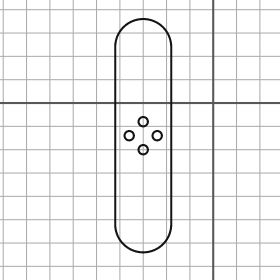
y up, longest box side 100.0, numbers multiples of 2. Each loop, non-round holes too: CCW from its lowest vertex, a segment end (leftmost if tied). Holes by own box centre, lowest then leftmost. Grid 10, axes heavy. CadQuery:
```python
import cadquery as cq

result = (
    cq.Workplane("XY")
    .moveTo(-42.0, -52.0)
    .threePointArc((-30.0, -64.0), (-18.0, -52.0))
    .lineTo(-18.0, 24.0)
    .threePointArc((-30.0, 36.0), (-42.0, 24.0))
    .close()
    .moveTo(-30.0, -20.0)
    .circle(2.0)
    .moveTo(-36.0, -14.0)
    .circle(2.0)
    .moveTo(-24.0, -14.0)
    .circle(2.0)
    .moveTo(-30.0, -8.0)
    .circle(2.0)
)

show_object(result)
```